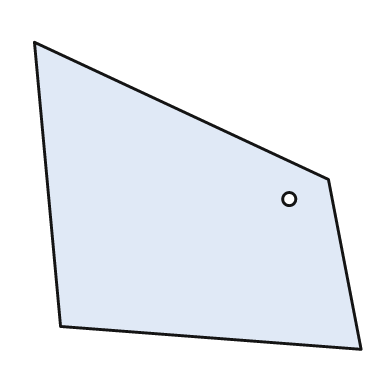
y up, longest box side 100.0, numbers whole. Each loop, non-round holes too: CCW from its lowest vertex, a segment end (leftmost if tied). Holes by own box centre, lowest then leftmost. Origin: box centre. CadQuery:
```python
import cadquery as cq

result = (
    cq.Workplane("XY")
    .moveTo(50.0, -47.0)
    .lineTo(40.0, 5.0)
    .lineTo(-50.0, 47.0)
    .lineTo(-42.0, -40.0)
    .close()
    .moveTo(28.0, -1.0)
    .circle(2.0)
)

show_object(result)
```